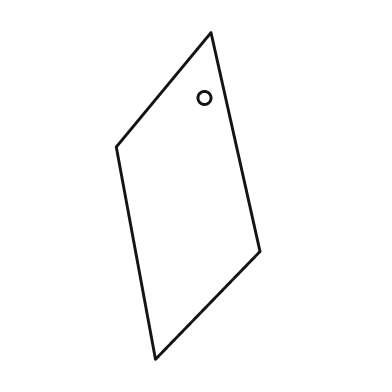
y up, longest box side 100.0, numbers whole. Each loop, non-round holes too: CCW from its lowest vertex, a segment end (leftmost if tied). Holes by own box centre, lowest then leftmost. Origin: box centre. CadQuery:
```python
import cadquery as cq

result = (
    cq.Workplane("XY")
    .moveTo(-10.0, -50.0)
    .lineTo(22.0, -17.0)
    .lineTo(7.0, 50.0)
    .lineTo(-22.0, 15.0)
    .close()
    .moveTo(5.0, 30.0)
    .circle(2.0)
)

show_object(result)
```